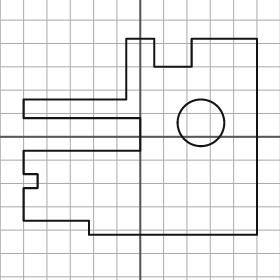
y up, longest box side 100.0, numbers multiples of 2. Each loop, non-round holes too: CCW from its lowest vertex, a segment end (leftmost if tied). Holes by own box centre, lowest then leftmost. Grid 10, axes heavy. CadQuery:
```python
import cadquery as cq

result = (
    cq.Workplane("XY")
    .moveTo(-22.0, -42.0)
    .lineTo(50.0, -42.0)
    .lineTo(50.0, 42.0)
    .lineTo(22.0, 42.0)
    .lineTo(22.0, 30.0)
    .lineTo(6.0, 30.0)
    .lineTo(6.0, 42.0)
    .lineTo(-6.0, 42.0)
    .lineTo(-6.0, 16.0)
    .lineTo(-50.0, 16.0)
    .lineTo(-50.0, 8.0)
    .lineTo(0.0, 8.0)
    .lineTo(0.0, -6.0)
    .lineTo(-50.0, -6.0)
    .lineTo(-50.0, -16.0)
    .lineTo(-44.0, -16.0)
    .lineTo(-44.0, -22.0)
    .lineTo(-50.0, -22.0)
    .lineTo(-50.0, -36.0)
    .lineTo(-22.0, -36.0)
    .close()
    .moveTo(26.0, 6.0)
    .circle(10.0)
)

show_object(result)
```